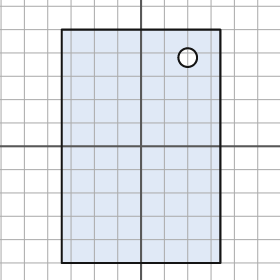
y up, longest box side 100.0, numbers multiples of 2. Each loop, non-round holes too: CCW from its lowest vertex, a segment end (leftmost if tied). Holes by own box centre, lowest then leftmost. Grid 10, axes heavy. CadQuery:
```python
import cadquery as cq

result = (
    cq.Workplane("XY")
    .moveTo(-34.0, -50.0)
    .lineTo(34.0, -50.0)
    .lineTo(34.0, 50.0)
    .lineTo(-34.0, 50.0)
    .close()
    .moveTo(20.0, 38.0)
    .circle(4.0)
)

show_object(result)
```